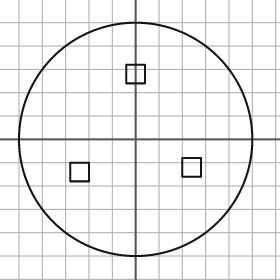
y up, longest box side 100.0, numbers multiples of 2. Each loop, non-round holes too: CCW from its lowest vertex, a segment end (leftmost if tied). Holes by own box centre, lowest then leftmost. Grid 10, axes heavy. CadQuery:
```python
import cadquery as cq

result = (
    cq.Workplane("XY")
    .moveTo(0.0, 0.0)
    .circle(50.0)
    .moveTo(-28.0, -18.0)
    .lineTo(-20.0, -18.0)
    .lineTo(-20.0, -10.0)
    .lineTo(-28.0, -10.0)
    .close()
    .moveTo(20.0, -16.0)
    .lineTo(28.0, -16.0)
    .lineTo(28.0, -8.0)
    .lineTo(20.0, -8.0)
    .close()
    .moveTo(-4.0, 24.0)
    .lineTo(4.0, 24.0)
    .lineTo(4.0, 32.0)
    .lineTo(-4.0, 32.0)
    .close()
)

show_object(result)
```